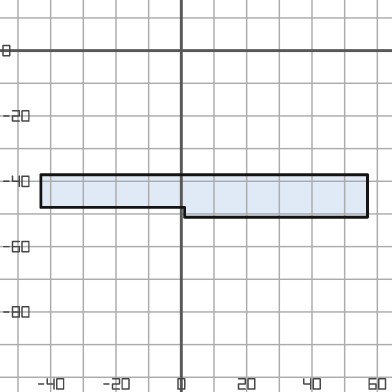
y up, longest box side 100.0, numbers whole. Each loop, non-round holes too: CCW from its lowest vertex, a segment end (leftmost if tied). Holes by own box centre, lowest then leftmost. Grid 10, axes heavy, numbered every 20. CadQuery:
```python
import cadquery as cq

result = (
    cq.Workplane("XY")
    .moveTo(1.0, -51.0)
    .lineTo(57.0, -51.0)
    .lineTo(57.0, -38.0)
    .lineTo(-43.0, -38.0)
    .lineTo(-43.0, -48.0)
    .lineTo(1.0, -48.0)
    .close()
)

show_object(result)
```